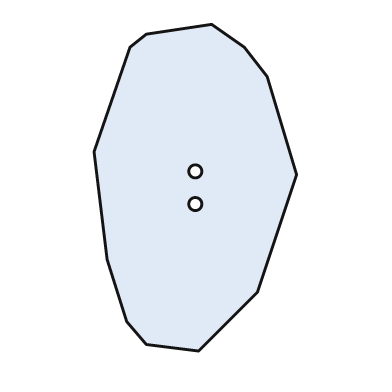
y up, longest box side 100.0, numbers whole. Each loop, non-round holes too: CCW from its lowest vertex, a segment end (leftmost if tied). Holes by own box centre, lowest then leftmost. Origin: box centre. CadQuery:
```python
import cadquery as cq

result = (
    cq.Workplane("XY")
    .moveTo(1.0, -50.0)
    .lineTo(19.0, -32.0)
    .lineTo(31.0, 4.0)
    .lineTo(22.0, 34.0)
    .lineTo(15.0, 43.0)
    .lineTo(5.0, 50.0)
    .lineTo(-15.0, 47.0)
    .lineTo(-20.0, 43.0)
    .lineTo(-31.0, 11.0)
    .lineTo(-27.0, -22.0)
    .lineTo(-21.0, -41.0)
    .lineTo(-15.0, -48.0)
    .close()
    .moveTo(0.0, -5.0)
    .circle(2.0)
    .moveTo(0.0, 5.0)
    .circle(2.0)
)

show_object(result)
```